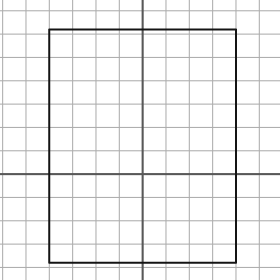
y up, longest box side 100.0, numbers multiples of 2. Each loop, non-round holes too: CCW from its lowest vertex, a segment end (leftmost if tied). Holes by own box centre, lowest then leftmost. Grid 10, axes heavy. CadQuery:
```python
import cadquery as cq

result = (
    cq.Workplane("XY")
    .moveTo(-40.0, -38.0)
    .lineTo(40.0, -38.0)
    .lineTo(40.0, 62.0)
    .lineTo(-40.0, 62.0)
    .close()
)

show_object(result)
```